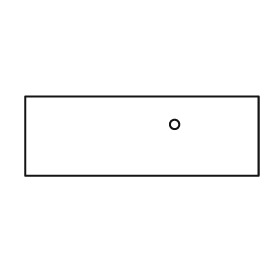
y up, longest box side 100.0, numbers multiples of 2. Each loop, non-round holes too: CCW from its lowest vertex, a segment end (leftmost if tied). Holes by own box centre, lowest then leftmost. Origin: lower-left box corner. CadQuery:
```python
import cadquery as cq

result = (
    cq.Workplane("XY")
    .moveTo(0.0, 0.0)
    .lineTo(100.0, 0.0)
    .lineTo(100.0, 34.0)
    .lineTo(0.0, 34.0)
    .close()
    .moveTo(64.0, 22.0)
    .circle(2.0)
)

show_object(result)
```